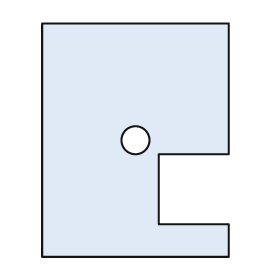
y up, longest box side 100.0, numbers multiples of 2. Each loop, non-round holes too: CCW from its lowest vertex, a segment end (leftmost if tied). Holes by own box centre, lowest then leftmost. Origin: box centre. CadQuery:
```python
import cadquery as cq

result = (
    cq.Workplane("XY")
    .moveTo(-40.0, -50.0)
    .lineTo(40.0, -50.0)
    .lineTo(40.0, -36.0)
    .lineTo(10.0, -36.0)
    .lineTo(10.0, -6.0)
    .lineTo(40.0, -6.0)
    .lineTo(40.0, 50.0)
    .lineTo(-40.0, 50.0)
    .close()
    .moveTo(0.0, 0.0)
    .circle(6.0)
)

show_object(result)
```